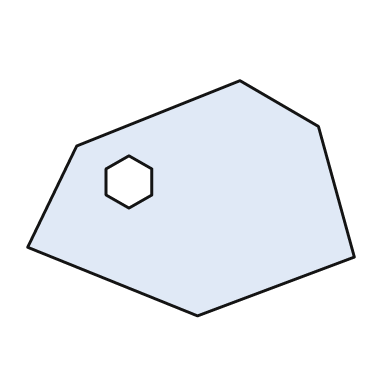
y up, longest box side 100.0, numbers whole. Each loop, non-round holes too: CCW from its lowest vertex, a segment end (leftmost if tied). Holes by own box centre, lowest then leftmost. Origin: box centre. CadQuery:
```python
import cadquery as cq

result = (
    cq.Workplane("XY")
    .moveTo(2.0, -36.0)
    .lineTo(50.0, -18.0)
    .lineTo(39.0, 22.0)
    .lineTo(15.0, 36.0)
    .lineTo(-35.0, 16.0)
    .lineTo(-50.0, -15.0)
    .close()
    .moveTo(-19.0, -3.0)
    .lineTo(-12.0, 1.0)
    .lineTo(-12.0, 9.0)
    .lineTo(-19.0, 13.0)
    .lineTo(-26.0, 9.0)
    .lineTo(-26.0, 1.0)
    .close()
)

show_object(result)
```